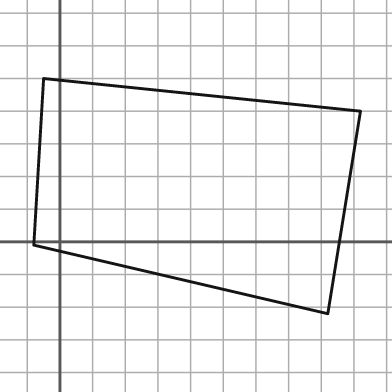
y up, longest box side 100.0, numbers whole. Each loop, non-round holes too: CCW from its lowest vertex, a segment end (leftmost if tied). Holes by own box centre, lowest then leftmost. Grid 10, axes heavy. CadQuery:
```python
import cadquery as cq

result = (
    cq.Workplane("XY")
    .moveTo(82.0, -22.0)
    .lineTo(92.0, 40.0)
    .lineTo(-5.0, 50.0)
    .lineTo(-8.0, -1.0)
    .close()
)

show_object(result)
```